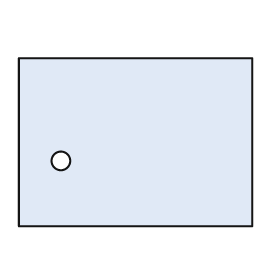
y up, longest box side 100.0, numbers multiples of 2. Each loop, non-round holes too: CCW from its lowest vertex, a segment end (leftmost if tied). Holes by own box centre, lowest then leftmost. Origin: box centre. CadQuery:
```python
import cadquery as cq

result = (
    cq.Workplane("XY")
    .moveTo(-50.0, -36.0)
    .lineTo(50.0, -36.0)
    .lineTo(50.0, 36.0)
    .lineTo(-50.0, 36.0)
    .close()
    .moveTo(-32.0, -8.0)
    .circle(4.0)
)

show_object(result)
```